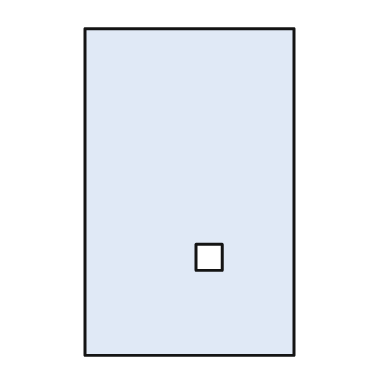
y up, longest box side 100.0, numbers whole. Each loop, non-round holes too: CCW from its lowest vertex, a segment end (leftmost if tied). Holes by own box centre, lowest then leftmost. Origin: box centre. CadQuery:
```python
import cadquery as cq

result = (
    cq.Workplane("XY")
    .moveTo(-32.0, -50.0)
    .lineTo(32.0, -50.0)
    .lineTo(32.0, 50.0)
    .lineTo(-32.0, 50.0)
    .close()
    .moveTo(2.0, -24.0)
    .lineTo(10.0, -24.0)
    .lineTo(10.0, -16.0)
    .lineTo(2.0, -16.0)
    .close()
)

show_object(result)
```